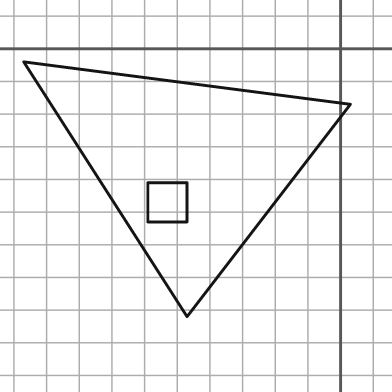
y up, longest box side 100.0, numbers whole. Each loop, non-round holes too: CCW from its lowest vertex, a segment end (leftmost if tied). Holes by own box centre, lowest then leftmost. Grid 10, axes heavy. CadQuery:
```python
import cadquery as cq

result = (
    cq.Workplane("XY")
    .moveTo(-47.0, -82.0)
    .lineTo(3.0, -17.0)
    .lineTo(-97.0, -4.0)
    .close()
    .moveTo(-59.0, -53.0)
    .lineTo(-47.0, -53.0)
    .lineTo(-47.0, -41.0)
    .lineTo(-59.0, -41.0)
    .close()
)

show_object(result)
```